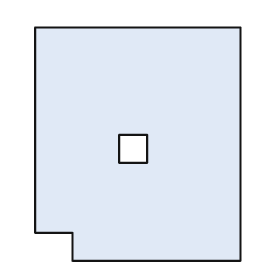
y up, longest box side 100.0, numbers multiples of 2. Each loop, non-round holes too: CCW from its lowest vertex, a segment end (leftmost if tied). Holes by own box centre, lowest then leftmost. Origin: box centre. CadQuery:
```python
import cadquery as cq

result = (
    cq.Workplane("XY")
    .moveTo(-28.0, -50.0)
    .lineTo(44.0, -50.0)
    .lineTo(44.0, 50.0)
    .lineTo(-44.0, 50.0)
    .lineTo(-44.0, -38.0)
    .lineTo(-28.0, -38.0)
    .close()
    .moveTo(-8.0, -8.0)
    .lineTo(4.0, -8.0)
    .lineTo(4.0, 4.0)
    .lineTo(-8.0, 4.0)
    .close()
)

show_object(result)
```